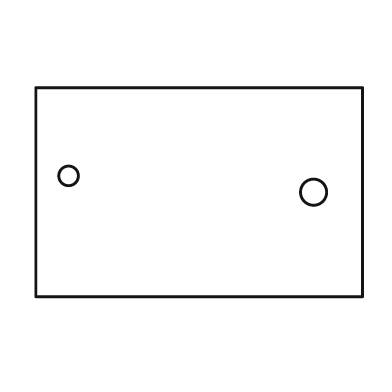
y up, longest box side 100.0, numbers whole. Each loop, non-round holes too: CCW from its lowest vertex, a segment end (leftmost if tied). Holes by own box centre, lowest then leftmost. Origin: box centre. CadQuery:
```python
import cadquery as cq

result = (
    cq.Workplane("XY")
    .moveTo(-50.0, -32.0)
    .lineTo(50.0, -32.0)
    .lineTo(50.0, 32.0)
    .lineTo(-50.0, 32.0)
    .close()
    .moveTo(35.0, 0.0)
    .circle(4.0)
    .moveTo(-40.0, 5.0)
    .circle(3.0)
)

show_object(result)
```